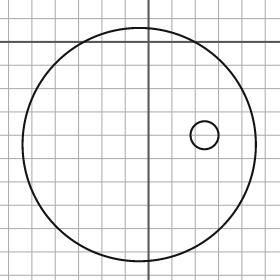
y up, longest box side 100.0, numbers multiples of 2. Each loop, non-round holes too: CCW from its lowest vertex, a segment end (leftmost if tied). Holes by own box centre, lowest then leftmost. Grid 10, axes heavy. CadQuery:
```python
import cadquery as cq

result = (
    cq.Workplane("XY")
    .moveTo(-4.0, -44.0)
    .circle(50.0)
    .moveTo(24.0, -40.0)
    .circle(6.0)
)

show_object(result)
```